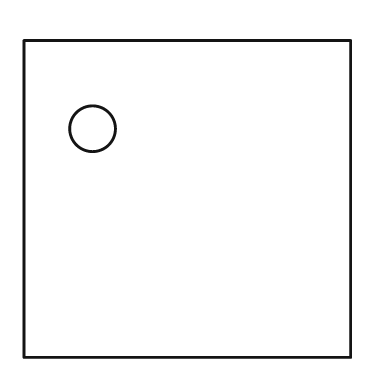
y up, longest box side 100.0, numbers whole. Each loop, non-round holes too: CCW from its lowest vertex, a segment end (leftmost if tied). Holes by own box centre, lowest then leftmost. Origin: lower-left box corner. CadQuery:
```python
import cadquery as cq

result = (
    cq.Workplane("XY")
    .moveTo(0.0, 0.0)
    .lineTo(100.0, 0.0)
    .lineTo(100.0, 97.0)
    .lineTo(0.0, 97.0)
    .close()
    .moveTo(21.0, 70.0)
    .circle(7.0)
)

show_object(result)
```